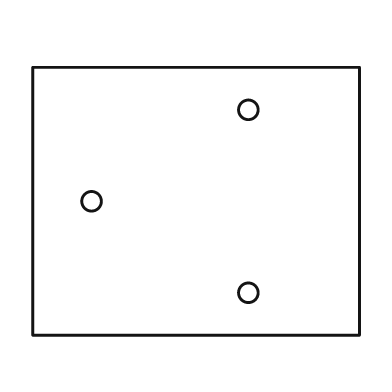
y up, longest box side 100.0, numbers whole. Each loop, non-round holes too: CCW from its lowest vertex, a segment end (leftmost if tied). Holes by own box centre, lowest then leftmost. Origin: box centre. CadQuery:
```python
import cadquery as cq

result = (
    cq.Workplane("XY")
    .moveTo(-50.0, -41.0)
    .lineTo(50.0, -41.0)
    .lineTo(50.0, 41.0)
    .lineTo(-50.0, 41.0)
    .close()
    .moveTo(16.0, -28.0)
    .circle(3.0)
    .moveTo(-32.0, 0.0)
    .circle(3.0)
    .moveTo(16.0, 28.0)
    .circle(3.0)
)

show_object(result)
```